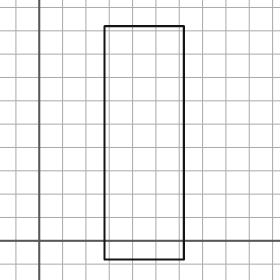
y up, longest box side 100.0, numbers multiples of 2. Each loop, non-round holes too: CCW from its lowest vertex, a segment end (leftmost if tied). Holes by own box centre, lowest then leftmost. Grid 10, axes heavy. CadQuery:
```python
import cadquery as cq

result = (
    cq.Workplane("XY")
    .moveTo(28.0, -8.0)
    .lineTo(62.0, -8.0)
    .lineTo(62.0, 92.0)
    .lineTo(28.0, 92.0)
    .close()
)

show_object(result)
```